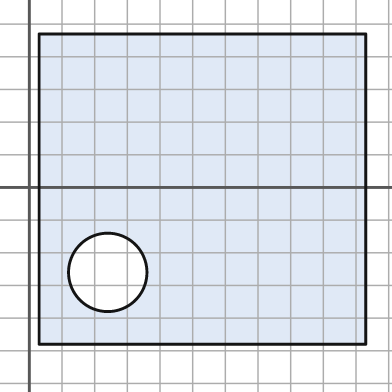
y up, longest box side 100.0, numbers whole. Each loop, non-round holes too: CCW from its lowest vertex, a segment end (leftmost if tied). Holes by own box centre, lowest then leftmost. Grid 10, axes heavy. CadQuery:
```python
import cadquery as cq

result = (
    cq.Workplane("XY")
    .moveTo(3.0, -48.0)
    .lineTo(103.0, -48.0)
    .lineTo(103.0, 47.0)
    .lineTo(3.0, 47.0)
    .close()
    .moveTo(24.0, -26.0)
    .circle(12.0)
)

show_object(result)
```